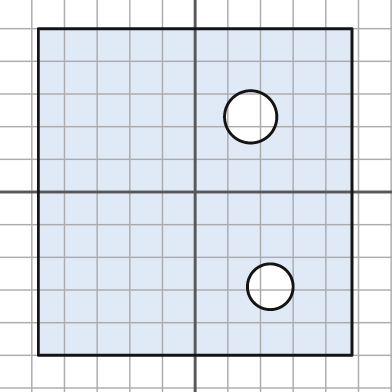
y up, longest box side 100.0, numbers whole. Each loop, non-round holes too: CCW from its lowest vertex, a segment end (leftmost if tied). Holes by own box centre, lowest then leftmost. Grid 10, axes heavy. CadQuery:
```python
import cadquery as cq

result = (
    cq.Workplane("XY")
    .moveTo(-48.0, -50.0)
    .lineTo(48.0, -50.0)
    .lineTo(48.0, 50.0)
    .lineTo(-48.0, 50.0)
    .close()
    .moveTo(23.0, -29.0)
    .circle(7.0)
    .moveTo(17.0, 23.0)
    .circle(8.0)
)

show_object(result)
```